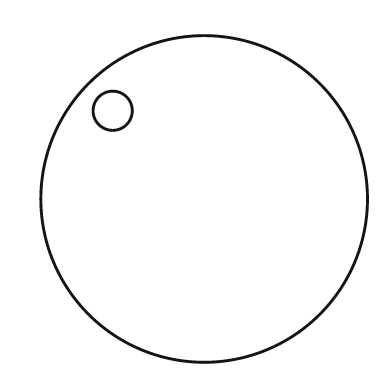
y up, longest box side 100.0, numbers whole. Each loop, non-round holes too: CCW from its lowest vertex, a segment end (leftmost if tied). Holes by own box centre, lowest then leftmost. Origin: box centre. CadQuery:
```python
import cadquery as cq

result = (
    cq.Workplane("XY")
    .moveTo(0.0, 0.0)
    .circle(50.0)
    .moveTo(-28.0, 27.0)
    .circle(6.0)
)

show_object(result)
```